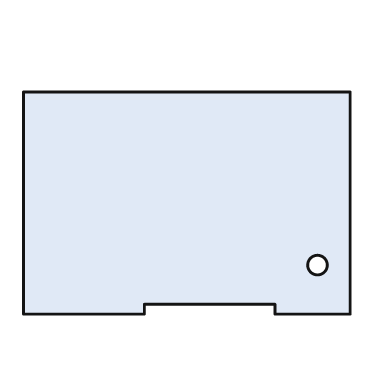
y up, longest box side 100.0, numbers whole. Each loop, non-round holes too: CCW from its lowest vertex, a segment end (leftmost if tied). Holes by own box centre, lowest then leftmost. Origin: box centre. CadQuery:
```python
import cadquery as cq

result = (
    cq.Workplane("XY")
    .moveTo(-50.0, -34.0)
    .lineTo(-13.0, -34.0)
    .lineTo(-13.0, -31.0)
    .lineTo(27.0, -31.0)
    .lineTo(27.0, -34.0)
    .lineTo(50.0, -34.0)
    .lineTo(50.0, 34.0)
    .lineTo(-50.0, 34.0)
    .close()
    .moveTo(40.0, -19.0)
    .circle(3.0)
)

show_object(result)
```